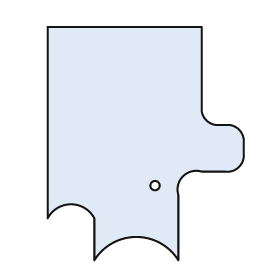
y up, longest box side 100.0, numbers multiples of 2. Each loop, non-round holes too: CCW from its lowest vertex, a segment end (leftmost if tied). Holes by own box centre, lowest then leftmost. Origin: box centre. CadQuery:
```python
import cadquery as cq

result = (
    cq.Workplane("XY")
    .moveTo(-22.0, -50.0)
    .threePointArc((-4.0, -40.0), (14.0, -50.0))
    .lineTo(14.0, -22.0)
    .threePointArc((16.0, -14.0), (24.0, -12.0))
    .lineTo(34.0, -12.0)
    .threePointArc((40.0, -10.0), (42.0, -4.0))
    .lineTo(42.0, 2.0)
    .threePointArc((40.0, 6.0), (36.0, 8.0))
    .lineTo(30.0, 8.0)
    .threePointArc((26.0, 10.0), (24.0, 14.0))
    .lineTo(24.0, 50.0)
    .lineTo(-42.0, 50.0)
    .lineTo(-42.0, -32.0)
    .threePointArc((-32.0, -26.0), (-22.0, -32.0))
    .close()
    .moveTo(4.0, -18.0)
    .circle(2.0)
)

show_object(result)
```